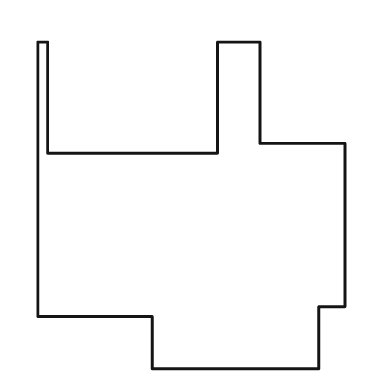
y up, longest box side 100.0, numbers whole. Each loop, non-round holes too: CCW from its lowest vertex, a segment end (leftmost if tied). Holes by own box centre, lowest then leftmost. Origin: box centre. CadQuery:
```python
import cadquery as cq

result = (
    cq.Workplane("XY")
    .moveTo(-12.0, -50.0)
    .lineTo(39.0, -50.0)
    .lineTo(39.0, -31.0)
    .lineTo(47.0, -31.0)
    .lineTo(47.0, 19.0)
    .lineTo(21.0, 19.0)
    .lineTo(21.0, 50.0)
    .lineTo(8.0, 50.0)
    .lineTo(8.0, 16.0)
    .lineTo(-44.0, 16.0)
    .lineTo(-44.0, 50.0)
    .lineTo(-47.0, 50.0)
    .lineTo(-47.0, -34.0)
    .lineTo(-12.0, -34.0)
    .close()
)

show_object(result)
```